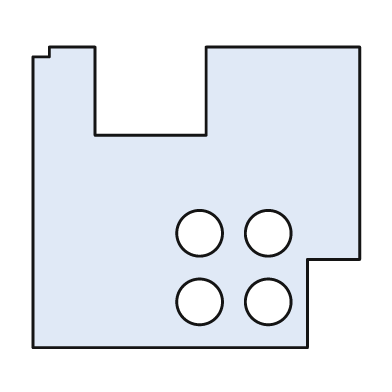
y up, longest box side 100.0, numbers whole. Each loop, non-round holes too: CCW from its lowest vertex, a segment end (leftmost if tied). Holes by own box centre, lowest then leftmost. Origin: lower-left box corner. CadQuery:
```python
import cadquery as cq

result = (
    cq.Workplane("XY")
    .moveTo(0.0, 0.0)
    .lineTo(84.0, 0.0)
    .lineTo(84.0, 27.0)
    .lineTo(100.0, 27.0)
    .lineTo(100.0, 92.0)
    .lineTo(53.0, 92.0)
    .lineTo(53.0, 65.0)
    .lineTo(19.0, 65.0)
    .lineTo(19.0, 92.0)
    .lineTo(5.0, 92.0)
    .lineTo(5.0, 89.0)
    .lineTo(0.0, 89.0)
    .close()
    .moveTo(51.0, 14.0)
    .circle(7.0)
    .moveTo(72.0, 14.0)
    .circle(7.0)
    .moveTo(51.0, 35.0)
    .circle(7.0)
    .moveTo(72.0, 35.0)
    .circle(7.0)
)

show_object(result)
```